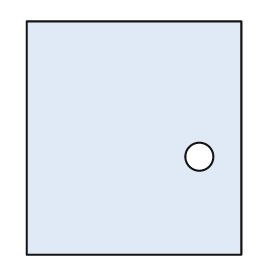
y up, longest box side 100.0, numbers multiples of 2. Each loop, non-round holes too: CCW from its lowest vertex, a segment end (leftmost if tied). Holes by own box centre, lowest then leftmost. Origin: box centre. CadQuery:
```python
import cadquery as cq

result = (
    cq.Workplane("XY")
    .moveTo(-46.0, -50.0)
    .lineTo(46.0, -50.0)
    .lineTo(46.0, 50.0)
    .lineTo(-46.0, 50.0)
    .close()
    .moveTo(28.0, -8.0)
    .circle(6.0)
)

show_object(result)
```